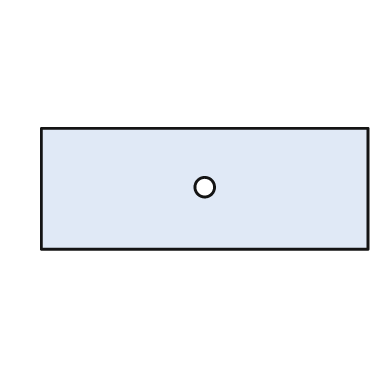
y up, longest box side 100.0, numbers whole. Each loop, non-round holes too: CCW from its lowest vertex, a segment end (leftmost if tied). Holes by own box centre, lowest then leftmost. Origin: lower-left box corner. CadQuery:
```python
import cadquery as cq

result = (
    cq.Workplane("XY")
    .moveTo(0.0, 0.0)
    .lineTo(100.0, 0.0)
    .lineTo(100.0, 37.0)
    .lineTo(0.0, 37.0)
    .close()
    .moveTo(50.0, 19.0)
    .circle(3.0)
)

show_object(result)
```